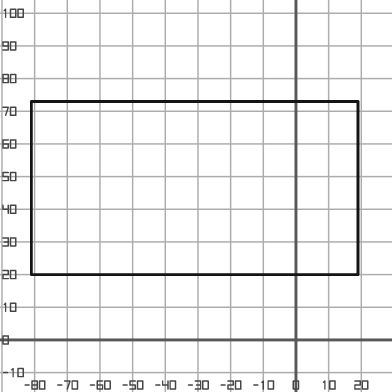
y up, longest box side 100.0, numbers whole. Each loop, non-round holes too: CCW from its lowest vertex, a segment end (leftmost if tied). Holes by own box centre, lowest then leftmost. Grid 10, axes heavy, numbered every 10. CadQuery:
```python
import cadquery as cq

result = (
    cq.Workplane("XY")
    .moveTo(-81.0, 20.0)
    .lineTo(19.0, 20.0)
    .lineTo(19.0, 73.0)
    .lineTo(-81.0, 73.0)
    .close()
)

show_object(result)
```